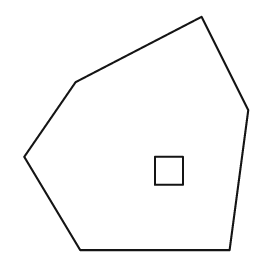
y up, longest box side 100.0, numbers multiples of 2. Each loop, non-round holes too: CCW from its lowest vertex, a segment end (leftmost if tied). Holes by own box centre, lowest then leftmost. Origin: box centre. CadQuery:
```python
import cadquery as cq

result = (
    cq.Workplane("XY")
    .moveTo(-24.0, -50.0)
    .lineTo(40.0, -50.0)
    .lineTo(48.0, 10.0)
    .lineTo(28.0, 50.0)
    .lineTo(-26.0, 22.0)
    .lineTo(-48.0, -10.0)
    .close()
    .moveTo(8.0, -22.0)
    .lineTo(20.0, -22.0)
    .lineTo(20.0, -10.0)
    .lineTo(8.0, -10.0)
    .close()
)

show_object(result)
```